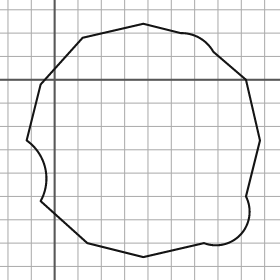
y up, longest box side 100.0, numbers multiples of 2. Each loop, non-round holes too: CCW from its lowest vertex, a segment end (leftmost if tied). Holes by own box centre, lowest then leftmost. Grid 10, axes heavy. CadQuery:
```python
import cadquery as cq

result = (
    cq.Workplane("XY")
    .moveTo(38.0, -76.0)
    .lineTo(64.0, -70.0)
    .threePointArc((80.0, -66.0), (82.0, -50.0))
    .lineTo(88.0, -26.0)
    .lineTo(82.0, 0.0)
    .lineTo(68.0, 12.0)
    .threePointArc((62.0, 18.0), (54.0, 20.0))
    .lineTo(38.0, 24.0)
    .lineTo(12.0, 18.0)
    .lineTo(-6.0, -2.0)
    .lineTo(-12.0, -26.0)
    .threePointArc((-4.0, -38.0), (-6.0, -52.0))
    .lineTo(14.0, -70.0)
    .close()
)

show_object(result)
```